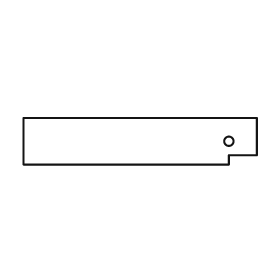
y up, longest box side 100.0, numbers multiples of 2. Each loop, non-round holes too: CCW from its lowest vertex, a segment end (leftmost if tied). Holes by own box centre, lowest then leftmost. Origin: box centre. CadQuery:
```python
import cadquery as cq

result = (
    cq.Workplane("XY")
    .moveTo(-50.0, -10.0)
    .lineTo(38.0, -10.0)
    .lineTo(38.0, -6.0)
    .lineTo(50.0, -6.0)
    .lineTo(50.0, 10.0)
    .lineTo(-50.0, 10.0)
    .close()
    .moveTo(38.0, 0.0)
    .circle(2.0)
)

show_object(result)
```